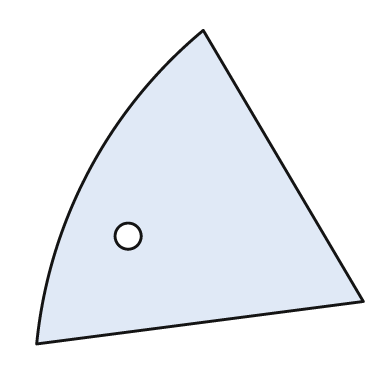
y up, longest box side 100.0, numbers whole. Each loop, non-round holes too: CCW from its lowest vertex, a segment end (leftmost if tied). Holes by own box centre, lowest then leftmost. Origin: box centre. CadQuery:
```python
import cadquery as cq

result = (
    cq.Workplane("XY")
    .moveTo(-50.0, -48.0)
    .lineTo(50.0, -35.0)
    .lineTo(1.0, 48.0)
    .threePointArc((-34.0, 5.0), (-50.0, -48.0))
    .close()
    .moveTo(-22.0, -15.0)
    .circle(4.0)
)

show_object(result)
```